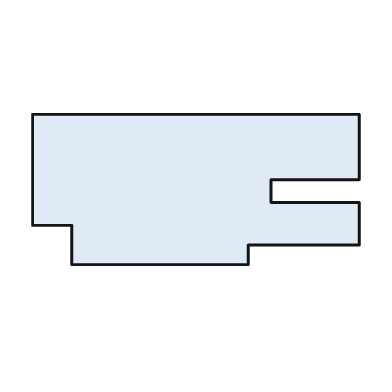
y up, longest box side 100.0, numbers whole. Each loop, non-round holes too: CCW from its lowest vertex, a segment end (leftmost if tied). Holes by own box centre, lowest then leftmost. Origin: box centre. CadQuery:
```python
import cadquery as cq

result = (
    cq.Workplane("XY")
    .moveTo(-38.0, -23.0)
    .lineTo(16.0, -23.0)
    .lineTo(16.0, -17.0)
    .lineTo(50.0, -17.0)
    .lineTo(50.0, -4.0)
    .lineTo(23.0, -4.0)
    .lineTo(23.0, 3.0)
    .lineTo(50.0, 3.0)
    .lineTo(50.0, 23.0)
    .lineTo(-50.0, 23.0)
    .lineTo(-50.0, -11.0)
    .lineTo(-38.0, -11.0)
    .close()
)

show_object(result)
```